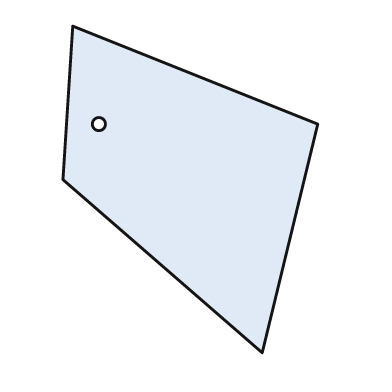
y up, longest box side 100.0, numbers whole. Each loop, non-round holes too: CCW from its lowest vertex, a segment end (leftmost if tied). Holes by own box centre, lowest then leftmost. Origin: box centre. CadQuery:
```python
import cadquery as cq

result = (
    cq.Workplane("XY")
    .moveTo(22.0, -50.0)
    .lineTo(39.0, 20.0)
    .lineTo(-36.0, 50.0)
    .lineTo(-39.0, 3.0)
    .close()
    .moveTo(-28.0, 20.0)
    .circle(2.0)
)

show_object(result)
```